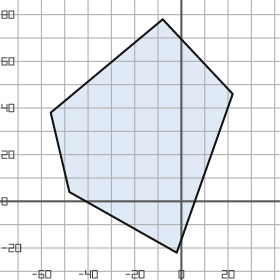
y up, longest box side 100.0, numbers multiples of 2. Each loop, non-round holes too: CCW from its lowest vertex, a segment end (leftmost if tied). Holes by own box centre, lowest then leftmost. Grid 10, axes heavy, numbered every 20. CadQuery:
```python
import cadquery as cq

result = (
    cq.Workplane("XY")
    .moveTo(-2.0, -22.0)
    .lineTo(22.0, 46.0)
    .lineTo(-8.0, 78.0)
    .lineTo(-56.0, 38.0)
    .lineTo(-48.0, 4.0)
    .close()
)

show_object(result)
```